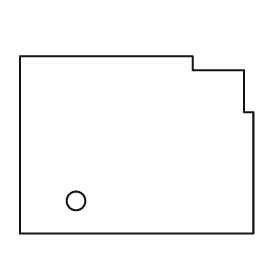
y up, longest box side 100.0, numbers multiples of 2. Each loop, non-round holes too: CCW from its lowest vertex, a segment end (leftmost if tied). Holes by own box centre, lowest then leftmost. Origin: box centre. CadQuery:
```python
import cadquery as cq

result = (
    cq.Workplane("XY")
    .moveTo(-50.0, -38.0)
    .lineTo(50.0, -38.0)
    .lineTo(50.0, 14.0)
    .lineTo(46.0, 14.0)
    .lineTo(46.0, 32.0)
    .lineTo(24.0, 32.0)
    .lineTo(24.0, 38.0)
    .lineTo(-50.0, 38.0)
    .close()
    .moveTo(-26.0, -24.0)
    .circle(4.0)
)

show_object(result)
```